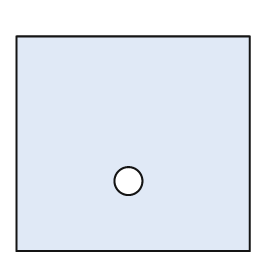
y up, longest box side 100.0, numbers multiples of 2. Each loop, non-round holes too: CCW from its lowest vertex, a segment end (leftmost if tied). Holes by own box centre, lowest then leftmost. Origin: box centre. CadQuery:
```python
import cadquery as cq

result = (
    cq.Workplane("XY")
    .moveTo(-50.0, -46.0)
    .lineTo(50.0, -46.0)
    .lineTo(50.0, 46.0)
    .lineTo(-50.0, 46.0)
    .close()
    .moveTo(-2.0, -16.0)
    .circle(6.0)
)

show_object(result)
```